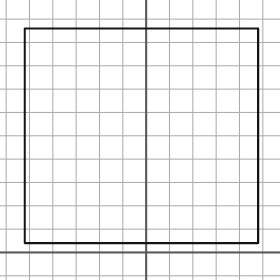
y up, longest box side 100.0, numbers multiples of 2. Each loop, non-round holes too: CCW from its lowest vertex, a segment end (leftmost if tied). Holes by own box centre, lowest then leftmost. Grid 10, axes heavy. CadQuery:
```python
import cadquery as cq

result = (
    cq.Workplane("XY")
    .moveTo(-52.0, 4.0)
    .lineTo(48.0, 4.0)
    .lineTo(48.0, 96.0)
    .lineTo(-52.0, 96.0)
    .close()
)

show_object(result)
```